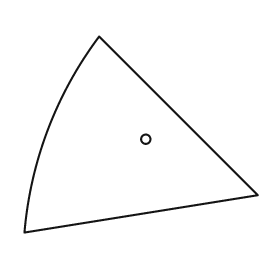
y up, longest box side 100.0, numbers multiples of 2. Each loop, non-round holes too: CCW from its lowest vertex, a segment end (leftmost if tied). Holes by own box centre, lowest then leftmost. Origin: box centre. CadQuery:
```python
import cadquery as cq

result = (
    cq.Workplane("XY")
    .moveTo(-50.0, -42.0)
    .lineTo(50.0, -26.0)
    .lineTo(-18.0, 42.0)
    .threePointArc((-40.0, 2.0), (-50.0, -42.0))
    .close()
    .moveTo(2.0, -2.0)
    .circle(2.0)
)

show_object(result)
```